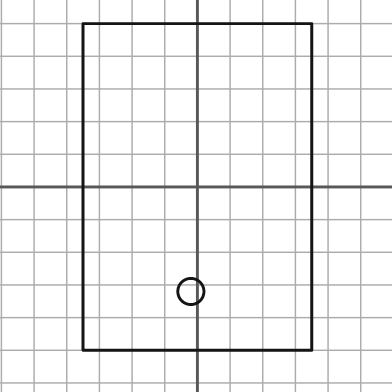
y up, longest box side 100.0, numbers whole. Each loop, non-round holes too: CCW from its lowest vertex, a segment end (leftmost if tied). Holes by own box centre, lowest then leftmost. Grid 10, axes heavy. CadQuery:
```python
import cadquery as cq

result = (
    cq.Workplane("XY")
    .moveTo(-35.0, -50.0)
    .lineTo(35.0, -50.0)
    .lineTo(35.0, 50.0)
    .lineTo(-35.0, 50.0)
    .close()
    .moveTo(-2.0, -32.0)
    .circle(4.0)
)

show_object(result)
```